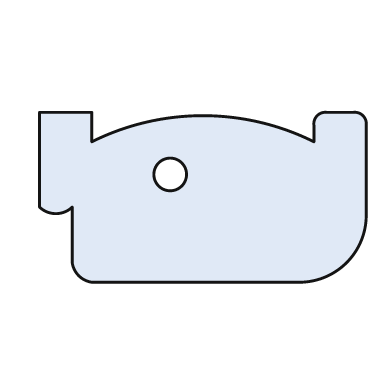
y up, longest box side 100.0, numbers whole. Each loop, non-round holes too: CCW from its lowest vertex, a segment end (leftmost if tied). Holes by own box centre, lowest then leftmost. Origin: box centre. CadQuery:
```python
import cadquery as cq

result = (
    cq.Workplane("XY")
    .moveTo(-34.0, -26.0)
    .lineTo(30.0, -26.0)
    .threePointArc((44.0, -20.0), (50.0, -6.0))
    .lineTo(50.0, 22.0)
    .threePointArc((49.0, 25.0), (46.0, 26.0))
    .lineTo(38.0, 26.0)
    .threePointArc((35.0, 25.0), (34.0, 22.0))
    .lineTo(34.0, 17.0)
    .threePointArc((0.0, 25.0), (-34.0, 17.0))
    .lineTo(-34.0, 26.0)
    .lineTo(-50.0, 26.0)
    .lineTo(-50.0, -3.0)
    .threePointArc((-45.0, -5.0), (-40.0, -3.0))
    .lineTo(-40.0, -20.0)
    .threePointArc((-38.0, -24.0), (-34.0, -26.0))
    .close()
    .moveTo(-10.0, 7.0)
    .circle(5.0)
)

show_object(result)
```